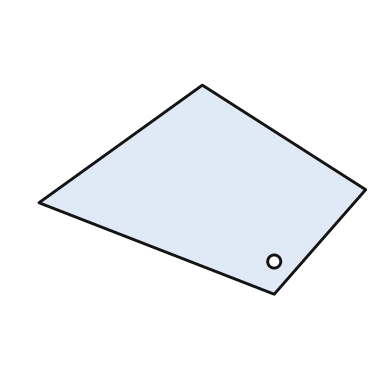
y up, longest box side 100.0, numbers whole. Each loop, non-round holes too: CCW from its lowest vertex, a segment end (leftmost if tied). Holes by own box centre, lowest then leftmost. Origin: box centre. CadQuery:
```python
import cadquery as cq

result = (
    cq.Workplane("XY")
    .moveTo(22.0, -32.0)
    .lineTo(50.0, 0.0)
    .lineTo(0.0, 32.0)
    .lineTo(-50.0, -4.0)
    .close()
    .moveTo(22.0, -22.0)
    .circle(2.0)
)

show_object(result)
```